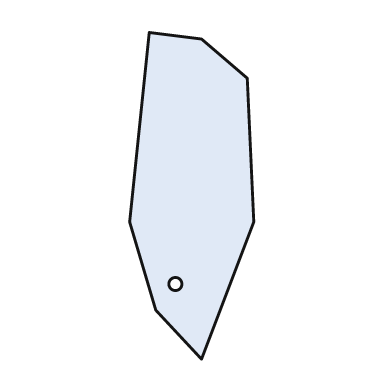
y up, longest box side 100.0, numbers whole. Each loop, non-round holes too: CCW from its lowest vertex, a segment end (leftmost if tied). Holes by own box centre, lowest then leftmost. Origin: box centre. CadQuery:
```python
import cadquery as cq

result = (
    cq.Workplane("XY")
    .moveTo(3.0, -50.0)
    .lineTo(19.0, -8.0)
    .lineTo(17.0, 36.0)
    .lineTo(3.0, 48.0)
    .lineTo(-13.0, 50.0)
    .lineTo(-19.0, -8.0)
    .lineTo(-11.0, -35.0)
    .close()
    .moveTo(-5.0, -27.0)
    .circle(2.0)
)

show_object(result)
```